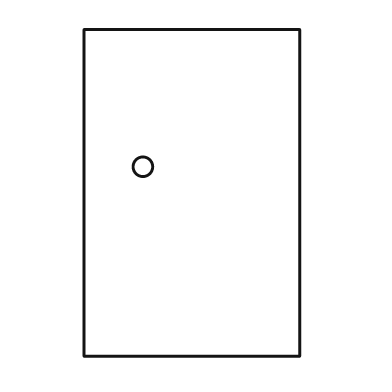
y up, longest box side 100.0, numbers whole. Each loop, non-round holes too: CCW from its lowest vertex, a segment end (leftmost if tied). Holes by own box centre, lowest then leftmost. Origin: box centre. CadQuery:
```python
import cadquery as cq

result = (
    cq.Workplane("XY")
    .moveTo(-33.0, -50.0)
    .lineTo(33.0, -50.0)
    .lineTo(33.0, 50.0)
    .lineTo(-33.0, 50.0)
    .close()
    .moveTo(-15.0, 8.0)
    .circle(3.0)
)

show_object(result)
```